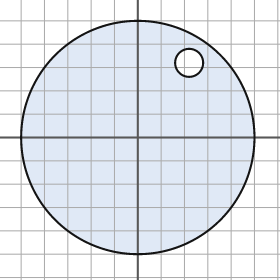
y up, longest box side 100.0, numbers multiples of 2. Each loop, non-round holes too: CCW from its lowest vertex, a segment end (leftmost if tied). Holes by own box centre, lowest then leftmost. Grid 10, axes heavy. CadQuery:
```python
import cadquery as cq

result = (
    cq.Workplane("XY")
    .moveTo(0.0, 0.0)
    .circle(50.0)
    .moveTo(22.0, 32.0)
    .circle(6.0)
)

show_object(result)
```